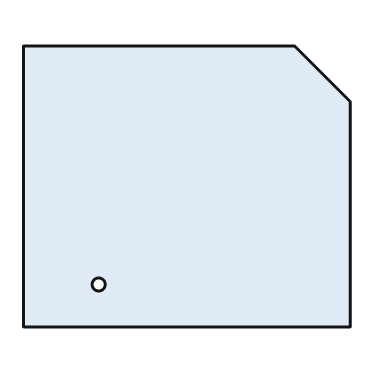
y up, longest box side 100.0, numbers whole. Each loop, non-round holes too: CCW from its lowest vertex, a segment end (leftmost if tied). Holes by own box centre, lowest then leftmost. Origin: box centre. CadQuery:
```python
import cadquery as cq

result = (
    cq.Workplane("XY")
    .moveTo(-50.0, -43.0)
    .lineTo(50.0, -43.0)
    .lineTo(50.0, 26.0)
    .lineTo(33.0, 43.0)
    .lineTo(-50.0, 43.0)
    .close()
    .moveTo(-27.0, -30.0)
    .circle(2.0)
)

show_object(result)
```